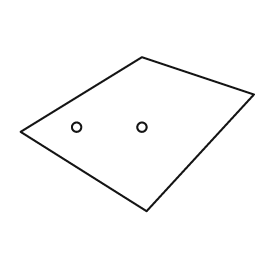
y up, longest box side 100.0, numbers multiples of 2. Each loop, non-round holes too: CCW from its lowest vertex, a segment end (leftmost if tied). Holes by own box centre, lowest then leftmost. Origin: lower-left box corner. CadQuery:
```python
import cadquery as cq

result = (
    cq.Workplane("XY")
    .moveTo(54.0, 0.0)
    .lineTo(100.0, 50.0)
    .lineTo(52.0, 66.0)
    .lineTo(0.0, 34.0)
    .close()
    .moveTo(24.0, 36.0)
    .circle(2.0)
    .moveTo(52.0, 36.0)
    .circle(2.0)
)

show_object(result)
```